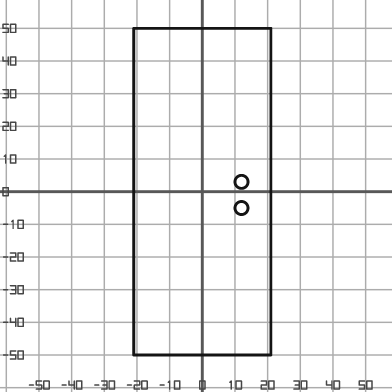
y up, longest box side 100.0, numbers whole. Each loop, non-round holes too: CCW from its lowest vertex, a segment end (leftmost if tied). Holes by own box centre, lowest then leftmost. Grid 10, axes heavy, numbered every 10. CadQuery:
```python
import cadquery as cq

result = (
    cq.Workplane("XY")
    .moveTo(-21.0, -50.0)
    .lineTo(21.0, -50.0)
    .lineTo(21.0, 50.0)
    .lineTo(-21.0, 50.0)
    .close()
    .moveTo(12.0, -5.0)
    .circle(2.0)
    .moveTo(12.0, 3.0)
    .circle(2.0)
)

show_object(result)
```